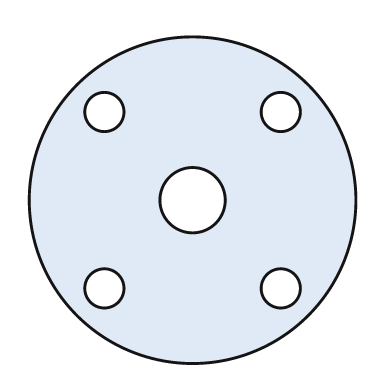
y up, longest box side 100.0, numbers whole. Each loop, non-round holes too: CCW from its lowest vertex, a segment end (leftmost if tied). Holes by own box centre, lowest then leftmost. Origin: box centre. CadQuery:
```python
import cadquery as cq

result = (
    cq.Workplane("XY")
    .moveTo(0.0, 0.0)
    .circle(50.0)
    .moveTo(-27.0, -27.0)
    .circle(6.0)
    .moveTo(27.0, -27.0)
    .circle(6.0)
    .moveTo(0.0, 0.0)
    .circle(10.0)
    .moveTo(-27.0, 27.0)
    .circle(6.0)
    .moveTo(27.0, 27.0)
    .circle(6.0)
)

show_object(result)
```